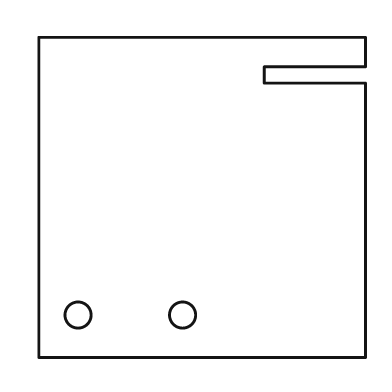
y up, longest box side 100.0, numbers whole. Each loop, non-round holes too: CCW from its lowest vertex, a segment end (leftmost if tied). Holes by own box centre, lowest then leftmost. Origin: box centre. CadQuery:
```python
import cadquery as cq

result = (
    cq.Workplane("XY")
    .moveTo(-50.0, -49.0)
    .lineTo(50.0, -49.0)
    .lineTo(50.0, 35.0)
    .lineTo(19.0, 35.0)
    .lineTo(19.0, 40.0)
    .lineTo(50.0, 40.0)
    .lineTo(50.0, 49.0)
    .lineTo(-50.0, 49.0)
    .close()
    .moveTo(-38.0, -36.0)
    .circle(4.0)
    .moveTo(-6.0, -36.0)
    .circle(4.0)
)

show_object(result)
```